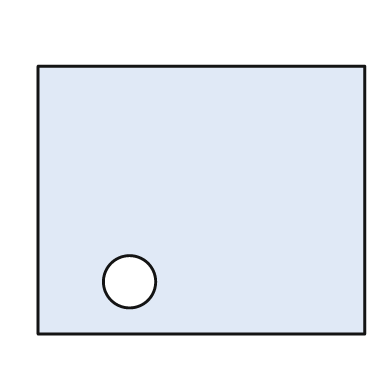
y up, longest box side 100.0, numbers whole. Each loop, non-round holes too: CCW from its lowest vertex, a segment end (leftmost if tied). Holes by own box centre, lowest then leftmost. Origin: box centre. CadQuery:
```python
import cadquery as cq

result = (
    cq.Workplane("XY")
    .moveTo(-50.0, -41.0)
    .lineTo(50.0, -41.0)
    .lineTo(50.0, 41.0)
    .lineTo(-50.0, 41.0)
    .close()
    .moveTo(-22.0, -25.0)
    .circle(8.0)
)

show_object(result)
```